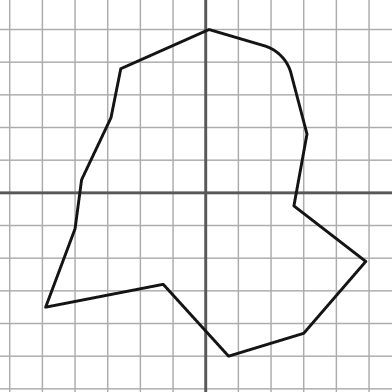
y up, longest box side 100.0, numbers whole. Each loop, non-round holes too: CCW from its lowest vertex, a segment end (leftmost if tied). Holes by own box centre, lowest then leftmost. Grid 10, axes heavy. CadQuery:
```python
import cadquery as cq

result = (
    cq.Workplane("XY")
    .moveTo(7.0, -50.0)
    .lineTo(30.0, -43.0)
    .lineTo(49.0, -21.0)
    .lineTo(27.0, -4.0)
    .lineTo(31.0, 18.0)
    .lineTo(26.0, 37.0)
    .threePointArc((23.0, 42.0), (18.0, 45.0))
    .lineTo(1.0, 50.0)
    .lineTo(-26.0, 38.0)
    .lineTo(-29.0, 23.0)
    .lineTo(-38.0, 4.0)
    .lineTo(-40.0, -11.0)
    .lineTo(-49.0, -35.0)
    .lineTo(-13.0, -28.0)
    .close()
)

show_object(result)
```